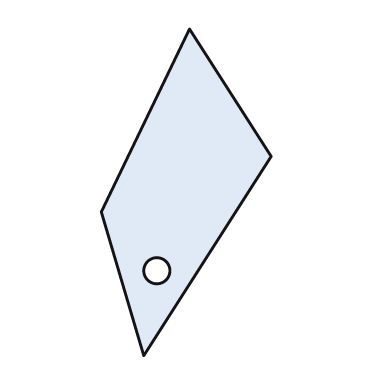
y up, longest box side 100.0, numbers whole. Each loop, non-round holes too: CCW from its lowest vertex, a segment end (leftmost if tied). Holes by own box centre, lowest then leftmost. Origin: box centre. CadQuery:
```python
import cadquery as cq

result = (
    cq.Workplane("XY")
    .moveTo(-13.0, -50.0)
    .lineTo(26.0, 11.0)
    .lineTo(1.0, 50.0)
    .lineTo(-26.0, -6.0)
    .close()
    .moveTo(-9.0, -24.0)
    .circle(4.0)
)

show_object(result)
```